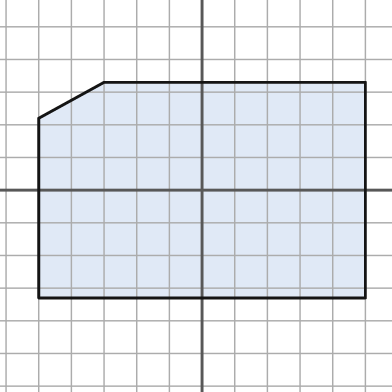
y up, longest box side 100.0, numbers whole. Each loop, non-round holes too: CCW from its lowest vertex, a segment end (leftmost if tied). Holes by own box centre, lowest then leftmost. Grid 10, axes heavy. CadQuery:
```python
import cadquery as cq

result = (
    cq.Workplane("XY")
    .moveTo(-50.0, -33.0)
    .lineTo(50.0, -33.0)
    .lineTo(50.0, 33.0)
    .lineTo(-30.0, 33.0)
    .lineTo(-50.0, 22.0)
    .close()
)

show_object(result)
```